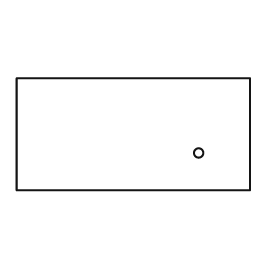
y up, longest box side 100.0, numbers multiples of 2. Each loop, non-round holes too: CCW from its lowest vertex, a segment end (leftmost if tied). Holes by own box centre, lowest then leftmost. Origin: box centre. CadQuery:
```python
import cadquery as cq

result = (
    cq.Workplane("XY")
    .moveTo(-50.0, -24.0)
    .lineTo(50.0, -24.0)
    .lineTo(50.0, 24.0)
    .lineTo(-50.0, 24.0)
    .close()
    .moveTo(28.0, -8.0)
    .circle(2.0)
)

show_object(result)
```